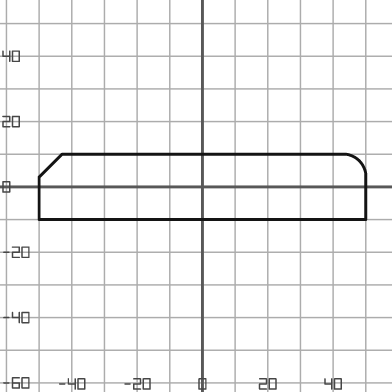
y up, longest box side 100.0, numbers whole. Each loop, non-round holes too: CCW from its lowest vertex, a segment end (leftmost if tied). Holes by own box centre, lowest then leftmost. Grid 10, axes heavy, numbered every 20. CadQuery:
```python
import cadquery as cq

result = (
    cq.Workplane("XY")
    .moveTo(-50.0, -10.0)
    .lineTo(50.0, -10.0)
    .lineTo(50.0, 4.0)
    .threePointArc((48.0, 8.0), (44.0, 10.0))
    .lineTo(-43.0, 10.0)
    .lineTo(-50.0, 3.0)
    .close()
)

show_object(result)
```